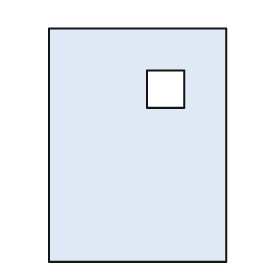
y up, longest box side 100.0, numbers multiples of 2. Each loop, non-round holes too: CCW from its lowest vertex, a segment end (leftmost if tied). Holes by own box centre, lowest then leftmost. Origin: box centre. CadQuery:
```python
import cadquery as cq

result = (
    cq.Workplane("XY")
    .moveTo(-38.0, -50.0)
    .lineTo(38.0, -50.0)
    .lineTo(38.0, 50.0)
    .lineTo(-38.0, 50.0)
    .close()
    .moveTo(4.0, 16.0)
    .lineTo(20.0, 16.0)
    .lineTo(20.0, 32.0)
    .lineTo(4.0, 32.0)
    .close()
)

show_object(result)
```